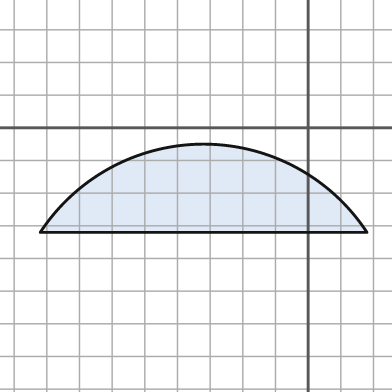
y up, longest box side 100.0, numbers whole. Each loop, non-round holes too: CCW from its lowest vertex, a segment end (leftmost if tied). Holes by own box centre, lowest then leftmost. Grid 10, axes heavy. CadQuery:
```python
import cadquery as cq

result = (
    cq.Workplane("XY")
    .moveTo(-82.0, -32.0)
    .lineTo(18.0, -32.0)
    .threePointArc((-32.0, -5.0), (-82.0, -32.0))
    .close()
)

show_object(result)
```